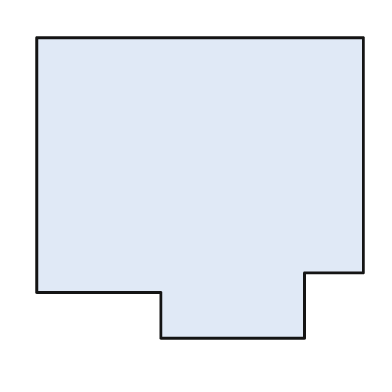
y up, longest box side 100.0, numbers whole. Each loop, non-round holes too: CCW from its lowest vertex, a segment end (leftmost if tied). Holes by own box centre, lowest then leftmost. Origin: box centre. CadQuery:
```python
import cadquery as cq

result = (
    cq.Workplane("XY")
    .moveTo(-12.0, -46.0)
    .lineTo(32.0, -46.0)
    .lineTo(32.0, -26.0)
    .lineTo(50.0, -26.0)
    .lineTo(50.0, 46.0)
    .lineTo(-50.0, 46.0)
    .lineTo(-50.0, -32.0)
    .lineTo(-12.0, -32.0)
    .close()
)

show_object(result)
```